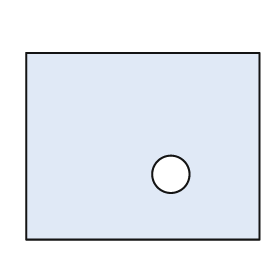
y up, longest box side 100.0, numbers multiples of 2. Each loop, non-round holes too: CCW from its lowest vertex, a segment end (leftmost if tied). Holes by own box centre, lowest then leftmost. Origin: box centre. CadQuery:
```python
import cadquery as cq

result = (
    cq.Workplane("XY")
    .moveTo(-50.0, -40.0)
    .lineTo(50.0, -40.0)
    .lineTo(50.0, 40.0)
    .lineTo(-50.0, 40.0)
    .close()
    .moveTo(12.0, -12.0)
    .circle(8.0)
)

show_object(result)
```